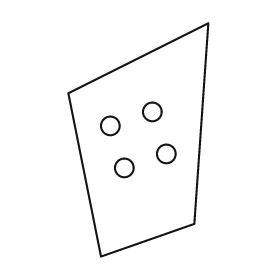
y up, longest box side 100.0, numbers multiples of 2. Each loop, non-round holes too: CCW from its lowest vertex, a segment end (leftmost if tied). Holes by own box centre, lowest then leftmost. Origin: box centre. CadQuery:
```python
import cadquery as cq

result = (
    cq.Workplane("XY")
    .moveTo(-16.0, -50.0)
    .lineTo(24.0, -36.0)
    .lineTo(30.0, 50.0)
    .lineTo(-30.0, 20.0)
    .close()
    .moveTo(-6.0, -12.0)
    .circle(4.0)
    .moveTo(12.0, -6.0)
    .circle(4.0)
    .moveTo(-12.0, 6.0)
    .circle(4.0)
    .moveTo(6.0, 12.0)
    .circle(4.0)
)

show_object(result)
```